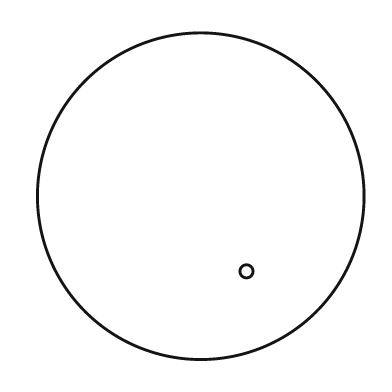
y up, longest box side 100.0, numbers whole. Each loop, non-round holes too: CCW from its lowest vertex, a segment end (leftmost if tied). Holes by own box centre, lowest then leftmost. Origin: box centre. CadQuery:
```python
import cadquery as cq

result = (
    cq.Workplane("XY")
    .moveTo(0.0, 0.0)
    .circle(50.0)
    .moveTo(14.0, -23.0)
    .circle(2.0)
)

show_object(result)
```